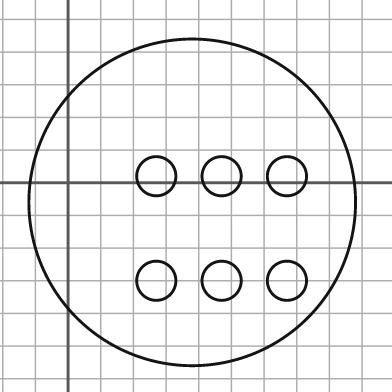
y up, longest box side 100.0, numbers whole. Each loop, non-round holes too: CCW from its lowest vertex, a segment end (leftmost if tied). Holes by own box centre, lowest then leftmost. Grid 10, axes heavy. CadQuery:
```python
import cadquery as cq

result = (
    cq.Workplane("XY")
    .moveTo(38.0, -6.0)
    .circle(50.0)
    .moveTo(27.0, -30.0)
    .circle(6.0)
    .moveTo(47.0, -30.0)
    .circle(6.0)
    .moveTo(67.0, -30.0)
    .circle(6.0)
    .moveTo(27.0, 2.0)
    .circle(6.0)
    .moveTo(47.0, 2.0)
    .circle(6.0)
    .moveTo(67.0, 2.0)
    .circle(6.0)
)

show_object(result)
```